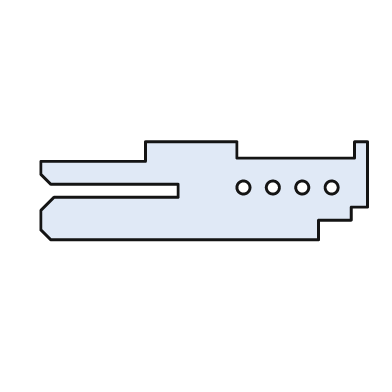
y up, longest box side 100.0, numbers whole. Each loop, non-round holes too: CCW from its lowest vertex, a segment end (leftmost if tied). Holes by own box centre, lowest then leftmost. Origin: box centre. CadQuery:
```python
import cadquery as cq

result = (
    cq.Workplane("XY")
    .moveTo(-47.0, -15.0)
    .lineTo(35.0, -15.0)
    .lineTo(35.0, -9.0)
    .lineTo(45.0, -9.0)
    .lineTo(45.0, -5.0)
    .lineTo(50.0, -5.0)
    .lineTo(50.0, 15.0)
    .lineTo(46.0, 15.0)
    .lineTo(46.0, 10.0)
    .lineTo(10.0, 10.0)
    .lineTo(10.0, 15.0)
    .lineTo(-18.0, 15.0)
    .lineTo(-18.0, 9.0)
    .lineTo(-50.0, 9.0)
    .lineTo(-50.0, 5.0)
    .lineTo(-47.0, 2.0)
    .lineTo(-8.0, 2.0)
    .lineTo(-8.0, -2.0)
    .lineTo(-46.0, -2.0)
    .lineTo(-50.0, -6.0)
    .lineTo(-50.0, -12.0)
    .close()
    .moveTo(12.0, 1.0)
    .circle(2.0)
    .moveTo(21.0, 1.0)
    .circle(2.0)
    .moveTo(30.0, 1.0)
    .circle(2.0)
    .moveTo(39.0, 1.0)
    .circle(2.0)
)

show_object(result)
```